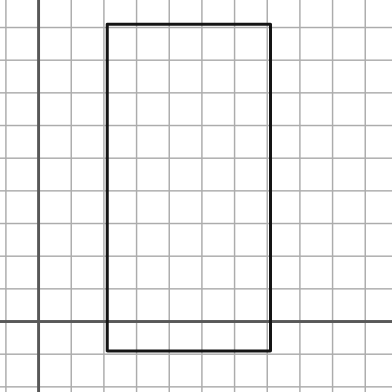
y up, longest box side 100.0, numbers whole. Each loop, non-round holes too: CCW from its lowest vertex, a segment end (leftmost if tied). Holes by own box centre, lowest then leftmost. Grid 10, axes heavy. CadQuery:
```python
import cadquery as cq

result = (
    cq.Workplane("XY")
    .moveTo(21.0, -9.0)
    .lineTo(71.0, -9.0)
    .lineTo(71.0, 91.0)
    .lineTo(21.0, 91.0)
    .close()
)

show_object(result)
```